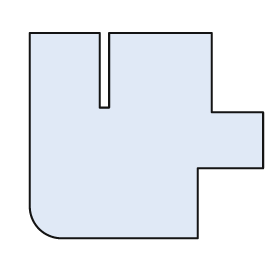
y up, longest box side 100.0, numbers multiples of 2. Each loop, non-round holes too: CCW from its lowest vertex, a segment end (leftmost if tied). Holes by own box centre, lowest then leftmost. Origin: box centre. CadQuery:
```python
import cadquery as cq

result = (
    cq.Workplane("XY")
    .moveTo(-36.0, -44.0)
    .lineTo(22.0, -44.0)
    .lineTo(22.0, -14.0)
    .lineTo(50.0, -14.0)
    .lineTo(50.0, 10.0)
    .lineTo(28.0, 10.0)
    .lineTo(28.0, 44.0)
    .lineTo(-16.0, 44.0)
    .lineTo(-16.0, 12.0)
    .lineTo(-20.0, 12.0)
    .lineTo(-20.0, 44.0)
    .lineTo(-50.0, 44.0)
    .lineTo(-50.0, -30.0)
    .threePointArc((-46.0, -40.0), (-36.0, -44.0))
    .close()
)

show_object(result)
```